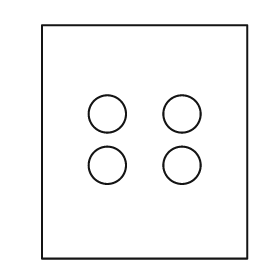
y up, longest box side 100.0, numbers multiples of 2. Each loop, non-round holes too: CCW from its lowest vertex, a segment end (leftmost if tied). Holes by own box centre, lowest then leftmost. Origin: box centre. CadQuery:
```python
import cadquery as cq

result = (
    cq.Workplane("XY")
    .moveTo(-44.0, -50.0)
    .lineTo(44.0, -50.0)
    .lineTo(44.0, 50.0)
    .lineTo(-44.0, 50.0)
    .close()
    .moveTo(-16.0, -10.0)
    .circle(8.0)
    .moveTo(16.0, -10.0)
    .circle(8.0)
    .moveTo(-16.0, 12.0)
    .circle(8.0)
    .moveTo(16.0, 12.0)
    .circle(8.0)
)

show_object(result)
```